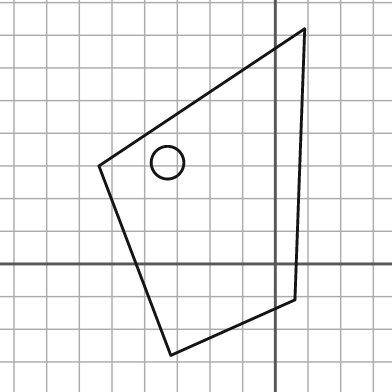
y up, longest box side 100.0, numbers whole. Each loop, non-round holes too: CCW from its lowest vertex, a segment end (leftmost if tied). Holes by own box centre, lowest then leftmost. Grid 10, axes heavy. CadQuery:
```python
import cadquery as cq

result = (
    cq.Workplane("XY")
    .moveTo(-32.0, -28.0)
    .lineTo(6.0, -11.0)
    .lineTo(9.0, 72.0)
    .lineTo(-54.0, 30.0)
    .close()
    .moveTo(-33.0, 31.0)
    .circle(5.0)
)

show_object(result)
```